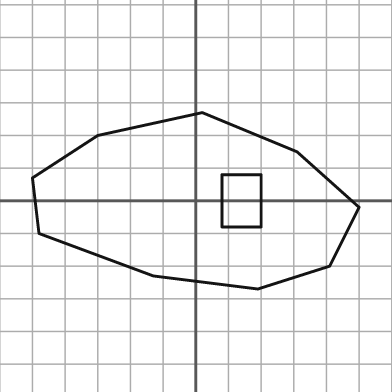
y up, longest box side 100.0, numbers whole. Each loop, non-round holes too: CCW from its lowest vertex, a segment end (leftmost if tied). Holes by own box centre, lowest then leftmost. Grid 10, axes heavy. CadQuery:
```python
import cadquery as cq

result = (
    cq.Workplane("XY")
    .moveTo(19.0, -27.0)
    .lineTo(41.0, -20.0)
    .lineTo(50.0, -2.0)
    .lineTo(31.0, 15.0)
    .lineTo(2.0, 27.0)
    .lineTo(-30.0, 20.0)
    .lineTo(-50.0, 7.0)
    .lineTo(-48.0, -10.0)
    .lineTo(-13.0, -23.0)
    .close()
    .moveTo(8.0, -8.0)
    .lineTo(20.0, -8.0)
    .lineTo(20.0, 8.0)
    .lineTo(8.0, 8.0)
    .close()
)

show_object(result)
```